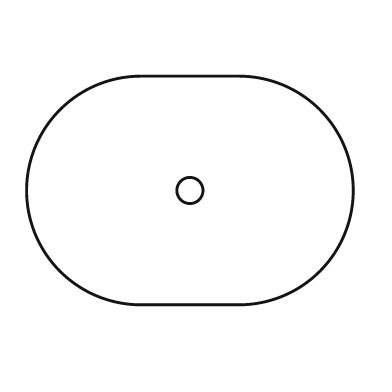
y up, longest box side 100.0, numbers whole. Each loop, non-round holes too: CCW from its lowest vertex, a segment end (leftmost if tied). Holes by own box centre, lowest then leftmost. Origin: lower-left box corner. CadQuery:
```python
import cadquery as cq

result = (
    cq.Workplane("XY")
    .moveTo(35.0, 0.0)
    .lineTo(65.0, 0.0)
    .threePointArc((100.0, 35.0), (65.0, 70.0))
    .lineTo(35.0, 70.0)
    .threePointArc((0.0, 35.0), (35.0, 0.0))
    .close()
    .moveTo(50.0, 35.0)
    .circle(4.0)
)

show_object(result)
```